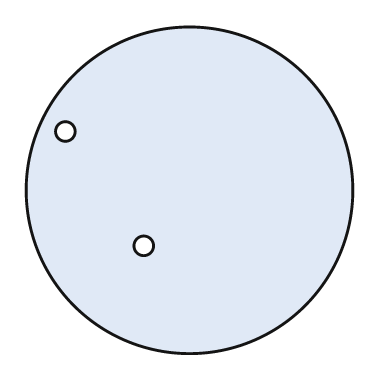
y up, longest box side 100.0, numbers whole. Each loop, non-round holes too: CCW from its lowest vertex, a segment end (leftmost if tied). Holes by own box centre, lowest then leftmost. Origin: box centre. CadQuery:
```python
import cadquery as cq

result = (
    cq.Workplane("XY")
    .moveTo(0.0, 0.0)
    .circle(50.0)
    .moveTo(-14.0, -17.0)
    .circle(3.0)
    .moveTo(-38.0, 18.0)
    .circle(3.0)
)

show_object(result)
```